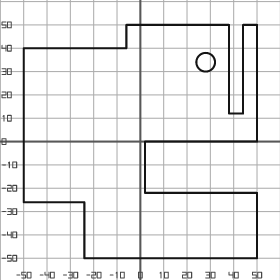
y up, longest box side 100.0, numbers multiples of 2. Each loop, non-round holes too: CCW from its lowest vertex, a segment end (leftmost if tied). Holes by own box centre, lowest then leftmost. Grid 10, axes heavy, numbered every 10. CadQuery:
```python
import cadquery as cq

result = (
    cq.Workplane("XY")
    .moveTo(-24.0, -50.0)
    .lineTo(50.0, -50.0)
    .lineTo(50.0, -22.0)
    .lineTo(2.0, -22.0)
    .lineTo(2.0, 0.0)
    .lineTo(50.0, 0.0)
    .lineTo(50.0, 50.0)
    .lineTo(44.0, 50.0)
    .lineTo(44.0, 12.0)
    .lineTo(38.0, 12.0)
    .lineTo(38.0, 50.0)
    .lineTo(-6.0, 50.0)
    .lineTo(-6.0, 40.0)
    .lineTo(-50.0, 40.0)
    .lineTo(-50.0, -26.0)
    .lineTo(-24.0, -26.0)
    .close()
    .moveTo(28.0, 34.0)
    .circle(4.0)
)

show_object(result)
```